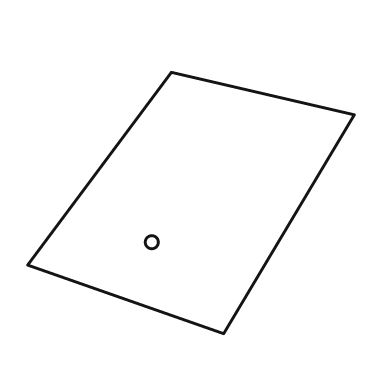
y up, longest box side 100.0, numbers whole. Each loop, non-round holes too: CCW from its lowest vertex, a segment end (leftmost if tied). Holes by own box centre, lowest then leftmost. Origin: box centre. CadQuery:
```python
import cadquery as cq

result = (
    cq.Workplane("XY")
    .moveTo(10.0, -40.0)
    .lineTo(50.0, 27.0)
    .lineTo(-6.0, 40.0)
    .lineTo(-50.0, -19.0)
    .close()
    .moveTo(-12.0, -12.0)
    .circle(2.0)
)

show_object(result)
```